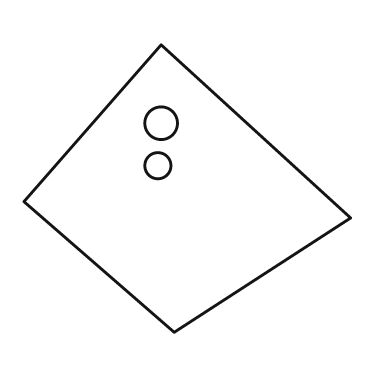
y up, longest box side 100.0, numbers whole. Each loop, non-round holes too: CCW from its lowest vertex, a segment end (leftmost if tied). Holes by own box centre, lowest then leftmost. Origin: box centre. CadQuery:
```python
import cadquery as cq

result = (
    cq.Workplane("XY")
    .moveTo(-4.0, -44.0)
    .lineTo(50.0, -9.0)
    .lineTo(-8.0, 44.0)
    .lineTo(-50.0, -4.0)
    .close()
    .moveTo(-9.0, 7.0)
    .circle(4.0)
    .moveTo(-8.0, 20.0)
    .circle(5.0)
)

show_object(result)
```